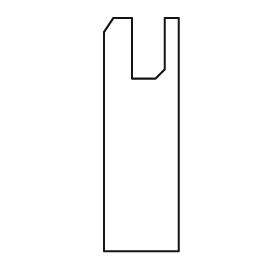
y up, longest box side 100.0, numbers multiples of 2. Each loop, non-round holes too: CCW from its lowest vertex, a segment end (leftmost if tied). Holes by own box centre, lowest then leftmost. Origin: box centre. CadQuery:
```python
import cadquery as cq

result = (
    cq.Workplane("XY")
    .moveTo(-16.0, -50.0)
    .lineTo(16.0, -50.0)
    .lineTo(16.0, 50.0)
    .lineTo(10.0, 50.0)
    .lineTo(10.0, 28.0)
    .lineTo(6.0, 24.0)
    .lineTo(-4.0, 24.0)
    .lineTo(-4.0, 50.0)
    .lineTo(-12.0, 50.0)
    .lineTo(-16.0, 44.0)
    .close()
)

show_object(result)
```